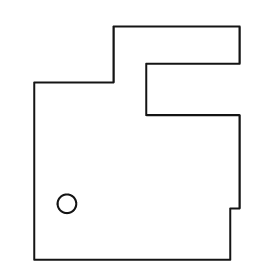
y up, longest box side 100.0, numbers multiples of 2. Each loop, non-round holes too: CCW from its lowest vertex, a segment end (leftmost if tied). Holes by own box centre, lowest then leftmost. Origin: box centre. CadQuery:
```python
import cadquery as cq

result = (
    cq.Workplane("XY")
    .moveTo(-44.0, -50.0)
    .lineTo(40.0, -50.0)
    .lineTo(40.0, -28.0)
    .lineTo(44.0, -28.0)
    .lineTo(44.0, 12.0)
    .lineTo(4.0, 12.0)
    .lineTo(4.0, 34.0)
    .lineTo(44.0, 34.0)
    .lineTo(44.0, 50.0)
    .lineTo(-10.0, 50.0)
    .lineTo(-10.0, 26.0)
    .lineTo(-44.0, 26.0)
    .close()
    .moveTo(-30.0, -26.0)
    .circle(4.0)
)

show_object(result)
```